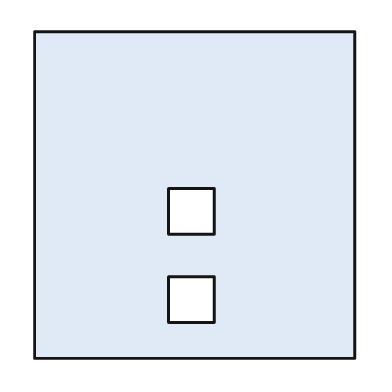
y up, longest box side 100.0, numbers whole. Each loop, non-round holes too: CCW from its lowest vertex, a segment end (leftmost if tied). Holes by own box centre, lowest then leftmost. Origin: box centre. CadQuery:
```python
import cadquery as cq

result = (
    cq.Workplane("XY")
    .moveTo(-49.0, -50.0)
    .lineTo(49.0, -50.0)
    .lineTo(49.0, 50.0)
    .lineTo(-49.0, 50.0)
    .close()
    .moveTo(-8.0, -39.0)
    .lineTo(6.0, -39.0)
    .lineTo(6.0, -25.0)
    .lineTo(-8.0, -25.0)
    .close()
    .moveTo(-8.0, -12.0)
    .lineTo(6.0, -12.0)
    .lineTo(6.0, 2.0)
    .lineTo(-8.0, 2.0)
    .close()
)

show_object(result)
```